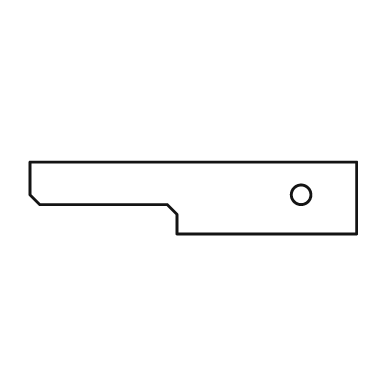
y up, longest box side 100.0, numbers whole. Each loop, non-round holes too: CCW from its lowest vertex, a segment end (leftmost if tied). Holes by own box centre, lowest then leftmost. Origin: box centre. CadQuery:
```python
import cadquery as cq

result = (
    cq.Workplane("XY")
    .moveTo(-5.0, -11.0)
    .lineTo(50.0, -11.0)
    .lineTo(50.0, 11.0)
    .lineTo(-50.0, 11.0)
    .lineTo(-50.0, 1.0)
    .lineTo(-47.0, -2.0)
    .lineTo(-8.0, -2.0)
    .lineTo(-5.0, -5.0)
    .close()
    .moveTo(33.0, 1.0)
    .circle(3.0)
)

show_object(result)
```